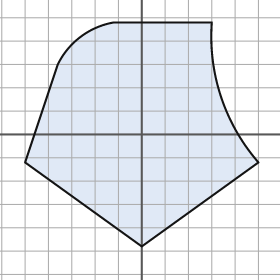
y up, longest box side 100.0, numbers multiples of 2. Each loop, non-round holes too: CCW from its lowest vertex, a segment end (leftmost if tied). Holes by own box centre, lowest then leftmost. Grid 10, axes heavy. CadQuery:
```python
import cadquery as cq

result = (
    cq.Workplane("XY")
    .moveTo(0.0, -48.0)
    .lineTo(50.0, -12.0)
    .threePointArc((34.0, 16.0), (30.0, 48.0))
    .lineTo(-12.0, 48.0)
    .threePointArc((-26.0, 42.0), (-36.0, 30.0))
    .lineTo(-50.0, -12.0)
    .close()
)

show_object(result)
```